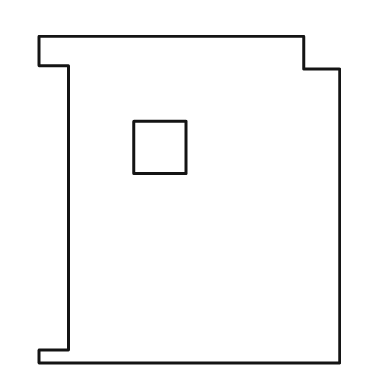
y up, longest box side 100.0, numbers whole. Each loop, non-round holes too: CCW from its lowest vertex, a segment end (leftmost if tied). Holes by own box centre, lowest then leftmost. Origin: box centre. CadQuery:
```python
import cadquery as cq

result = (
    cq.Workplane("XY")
    .moveTo(-46.0, -50.0)
    .lineTo(46.0, -50.0)
    .lineTo(46.0, 40.0)
    .lineTo(35.0, 40.0)
    .lineTo(35.0, 50.0)
    .lineTo(-46.0, 50.0)
    .lineTo(-46.0, 41.0)
    .lineTo(-37.0, 41.0)
    .lineTo(-37.0, -46.0)
    .lineTo(-46.0, -46.0)
    .close()
    .moveTo(-17.0, 8.0)
    .lineTo(-1.0, 8.0)
    .lineTo(-1.0, 24.0)
    .lineTo(-17.0, 24.0)
    .close()
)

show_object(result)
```